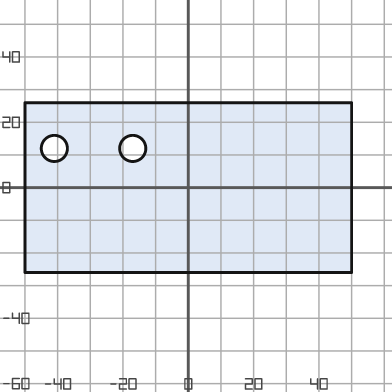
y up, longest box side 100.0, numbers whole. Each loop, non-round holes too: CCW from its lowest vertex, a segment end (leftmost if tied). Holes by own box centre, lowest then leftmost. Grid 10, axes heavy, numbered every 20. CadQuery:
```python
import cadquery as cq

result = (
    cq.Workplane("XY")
    .moveTo(-50.0, -26.0)
    .lineTo(50.0, -26.0)
    .lineTo(50.0, 26.0)
    .lineTo(-50.0, 26.0)
    .close()
    .moveTo(-41.0, 12.0)
    .circle(4.0)
    .moveTo(-17.0, 12.0)
    .circle(4.0)
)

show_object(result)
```